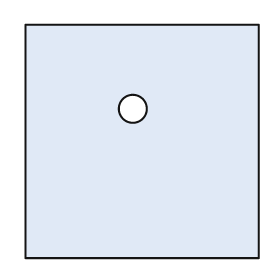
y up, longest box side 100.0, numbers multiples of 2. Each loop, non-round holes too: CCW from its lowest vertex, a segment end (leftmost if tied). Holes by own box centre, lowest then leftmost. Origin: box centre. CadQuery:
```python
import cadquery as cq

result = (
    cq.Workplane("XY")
    .moveTo(-50.0, -50.0)
    .lineTo(50.0, -50.0)
    .lineTo(50.0, 50.0)
    .lineTo(-50.0, 50.0)
    .close()
    .moveTo(-4.0, 14.0)
    .circle(6.0)
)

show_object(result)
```